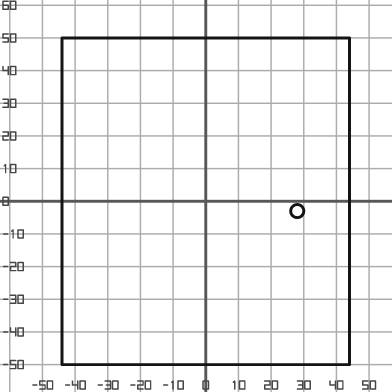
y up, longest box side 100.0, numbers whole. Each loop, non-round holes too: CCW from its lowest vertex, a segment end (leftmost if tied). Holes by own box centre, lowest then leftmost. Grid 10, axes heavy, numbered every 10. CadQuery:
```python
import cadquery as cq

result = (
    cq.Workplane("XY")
    .moveTo(-44.0, -50.0)
    .lineTo(44.0, -50.0)
    .lineTo(44.0, 50.0)
    .lineTo(-44.0, 50.0)
    .close()
    .moveTo(28.0, -3.0)
    .circle(2.0)
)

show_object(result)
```